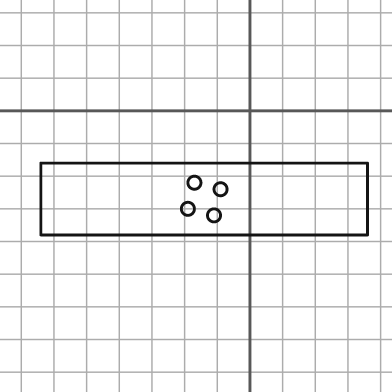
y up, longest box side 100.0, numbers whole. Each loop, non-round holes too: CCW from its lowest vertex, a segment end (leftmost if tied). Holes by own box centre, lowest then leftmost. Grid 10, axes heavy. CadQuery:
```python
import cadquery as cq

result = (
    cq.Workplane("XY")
    .moveTo(-64.0, -38.0)
    .lineTo(36.0, -38.0)
    .lineTo(36.0, -16.0)
    .lineTo(-64.0, -16.0)
    .close()
    .moveTo(-11.0, -32.0)
    .circle(2.0)
    .moveTo(-19.0, -30.0)
    .circle(2.0)
    .moveTo(-9.0, -24.0)
    .circle(2.0)
    .moveTo(-17.0, -22.0)
    .circle(2.0)
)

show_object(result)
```